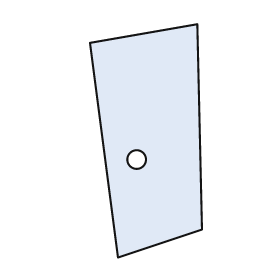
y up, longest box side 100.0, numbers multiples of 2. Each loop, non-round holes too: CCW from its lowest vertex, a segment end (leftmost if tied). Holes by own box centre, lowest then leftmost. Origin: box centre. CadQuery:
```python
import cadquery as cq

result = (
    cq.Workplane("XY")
    .moveTo(-12.0, -50.0)
    .lineTo(24.0, -38.0)
    .lineTo(22.0, 50.0)
    .lineTo(-24.0, 42.0)
    .close()
    .moveTo(-4.0, -8.0)
    .circle(4.0)
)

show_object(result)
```